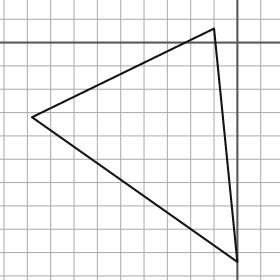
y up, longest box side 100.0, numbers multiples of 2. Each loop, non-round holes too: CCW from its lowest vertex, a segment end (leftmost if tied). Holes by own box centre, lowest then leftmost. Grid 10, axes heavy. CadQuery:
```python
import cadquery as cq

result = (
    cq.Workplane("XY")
    .moveTo(0.0, -94.0)
    .lineTo(-10.0, 6.0)
    .lineTo(-88.0, -32.0)
    .close()
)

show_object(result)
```